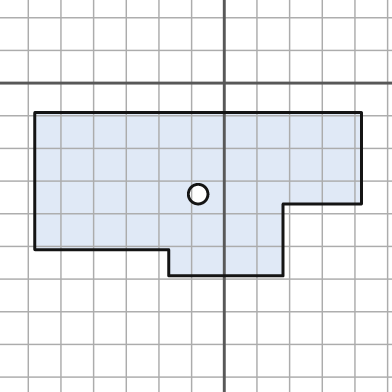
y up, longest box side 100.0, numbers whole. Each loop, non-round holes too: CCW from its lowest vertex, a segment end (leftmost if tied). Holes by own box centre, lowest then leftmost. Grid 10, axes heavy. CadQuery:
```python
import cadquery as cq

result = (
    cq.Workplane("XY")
    .moveTo(-17.0, -59.0)
    .lineTo(18.0, -59.0)
    .lineTo(18.0, -37.0)
    .lineTo(42.0, -37.0)
    .lineTo(42.0, -9.0)
    .lineTo(-58.0, -9.0)
    .lineTo(-58.0, -51.0)
    .lineTo(-17.0, -51.0)
    .close()
    .moveTo(-8.0, -34.0)
    .circle(3.0)
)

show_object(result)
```